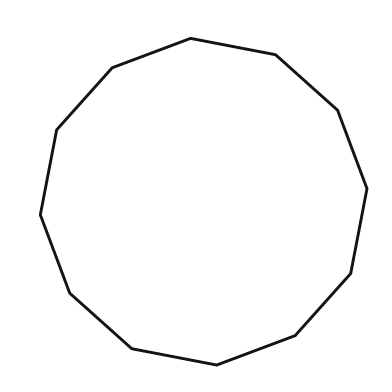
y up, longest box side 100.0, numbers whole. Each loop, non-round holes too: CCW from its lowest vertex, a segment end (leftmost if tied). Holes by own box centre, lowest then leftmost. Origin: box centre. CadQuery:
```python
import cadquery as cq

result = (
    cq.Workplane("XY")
    .moveTo(4.0, -50.0)
    .lineTo(28.0, -41.0)
    .lineTo(45.0, -22.0)
    .lineTo(50.0, 4.0)
    .lineTo(41.0, 28.0)
    .lineTo(22.0, 45.0)
    .lineTo(-4.0, 50.0)
    .lineTo(-28.0, 41.0)
    .lineTo(-45.0, 22.0)
    .lineTo(-50.0, -4.0)
    .lineTo(-41.0, -28.0)
    .lineTo(-22.0, -45.0)
    .close()
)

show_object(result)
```